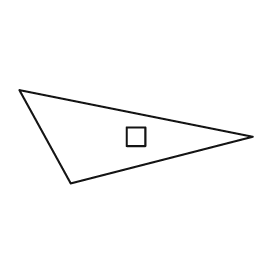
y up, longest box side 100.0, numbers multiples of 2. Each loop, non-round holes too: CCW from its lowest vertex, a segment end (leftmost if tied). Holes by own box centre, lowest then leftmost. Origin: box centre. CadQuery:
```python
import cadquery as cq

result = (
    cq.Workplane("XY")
    .moveTo(-28.0, -20.0)
    .lineTo(50.0, 0.0)
    .lineTo(-50.0, 20.0)
    .close()
    .moveTo(-4.0, -4.0)
    .lineTo(4.0, -4.0)
    .lineTo(4.0, 4.0)
    .lineTo(-4.0, 4.0)
    .close()
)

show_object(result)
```